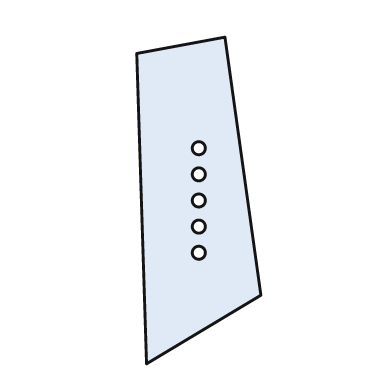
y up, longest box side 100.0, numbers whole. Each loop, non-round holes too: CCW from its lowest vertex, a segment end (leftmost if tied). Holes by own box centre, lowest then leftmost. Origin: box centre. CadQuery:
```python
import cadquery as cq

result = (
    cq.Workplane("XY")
    .moveTo(-16.0, -50.0)
    .lineTo(19.0, -29.0)
    .lineTo(8.0, 50.0)
    .lineTo(-19.0, 45.0)
    .close()
    .moveTo(0.0, -16.0)
    .circle(2.0)
    .moveTo(0.0, -8.0)
    .circle(2.0)
    .moveTo(0.0, 0.0)
    .circle(2.0)
    .moveTo(0.0, 8.0)
    .circle(2.0)
    .moveTo(0.0, 16.0)
    .circle(2.0)
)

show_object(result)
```